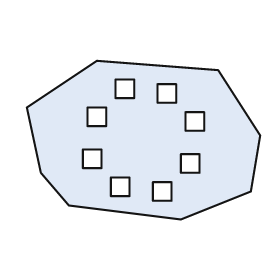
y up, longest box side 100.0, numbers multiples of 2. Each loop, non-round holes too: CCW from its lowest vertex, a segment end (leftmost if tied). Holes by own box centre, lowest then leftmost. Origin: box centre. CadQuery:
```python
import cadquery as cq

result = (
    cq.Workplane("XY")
    .moveTo(16.0, -34.0)
    .lineTo(46.0, -22.0)
    .lineTo(50.0, 2.0)
    .lineTo(32.0, 30.0)
    .lineTo(-20.0, 34.0)
    .lineTo(-50.0, 14.0)
    .lineTo(-44.0, -14.0)
    .lineTo(-32.0, -28.0)
    .close()
    .moveTo(4.0, -26.0)
    .lineTo(12.0, -26.0)
    .lineTo(12.0, -18.0)
    .lineTo(4.0, -18.0)
    .close()
    .moveTo(-14.0, -24.0)
    .lineTo(-6.0, -24.0)
    .lineTo(-6.0, -16.0)
    .lineTo(-14.0, -16.0)
    .close()
    .moveTo(16.0, -14.0)
    .lineTo(24.0, -14.0)
    .lineTo(24.0, -6.0)
    .lineTo(16.0, -6.0)
    .close()
    .moveTo(-26.0, -12.0)
    .lineTo(-18.0, -12.0)
    .lineTo(-18.0, -4.0)
    .lineTo(-26.0, -4.0)
    .close()
    .moveTo(18.0, 4.0)
    .lineTo(26.0, 4.0)
    .lineTo(26.0, 12.0)
    .lineTo(18.0, 12.0)
    .close()
    .moveTo(-24.0, 6.0)
    .lineTo(-16.0, 6.0)
    .lineTo(-16.0, 14.0)
    .lineTo(-24.0, 14.0)
    .close()
    .moveTo(6.0, 16.0)
    .lineTo(14.0, 16.0)
    .lineTo(14.0, 24.0)
    .lineTo(6.0, 24.0)
    .close()
    .moveTo(-12.0, 18.0)
    .lineTo(-4.0, 18.0)
    .lineTo(-4.0, 26.0)
    .lineTo(-12.0, 26.0)
    .close()
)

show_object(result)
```